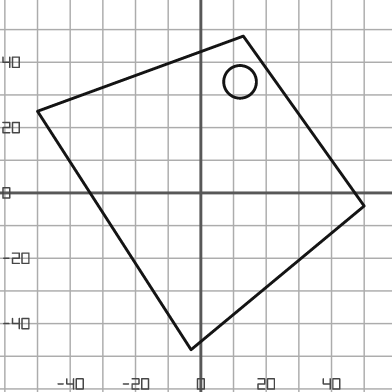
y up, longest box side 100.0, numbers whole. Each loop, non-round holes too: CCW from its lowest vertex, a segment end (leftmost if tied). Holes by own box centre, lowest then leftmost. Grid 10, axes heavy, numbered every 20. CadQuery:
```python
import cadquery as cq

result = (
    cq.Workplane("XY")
    .moveTo(-3.0, -48.0)
    .lineTo(50.0, -4.0)
    .lineTo(13.0, 48.0)
    .lineTo(-50.0, 25.0)
    .close()
    .moveTo(12.0, 34.0)
    .circle(5.0)
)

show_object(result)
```